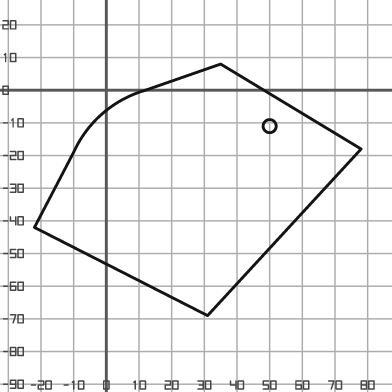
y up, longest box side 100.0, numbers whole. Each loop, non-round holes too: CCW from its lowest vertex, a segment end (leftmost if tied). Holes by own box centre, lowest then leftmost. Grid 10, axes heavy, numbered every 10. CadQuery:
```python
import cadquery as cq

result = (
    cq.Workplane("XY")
    .moveTo(31.0, -69.0)
    .lineTo(78.0, -18.0)
    .lineTo(35.0, 8.0)
    .lineTo(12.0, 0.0)
    .threePointArc((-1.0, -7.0), (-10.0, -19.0))
    .lineTo(-22.0, -42.0)
    .close()
    .moveTo(50.0, -11.0)
    .circle(2.0)
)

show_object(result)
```